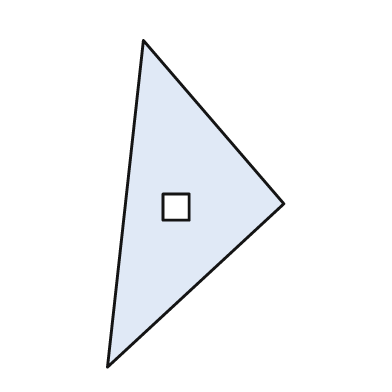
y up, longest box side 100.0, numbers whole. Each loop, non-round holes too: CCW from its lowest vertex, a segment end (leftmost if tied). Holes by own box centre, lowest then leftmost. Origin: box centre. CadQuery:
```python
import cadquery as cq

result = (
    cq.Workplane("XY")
    .moveTo(-27.0, -50.0)
    .lineTo(27.0, 0.0)
    .lineTo(-16.0, 50.0)
    .close()
    .moveTo(-10.0, -5.0)
    .lineTo(-2.0, -5.0)
    .lineTo(-2.0, 3.0)
    .lineTo(-10.0, 3.0)
    .close()
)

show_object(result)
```